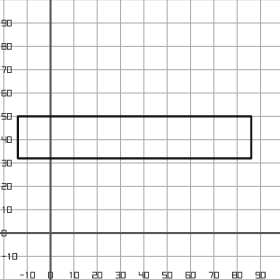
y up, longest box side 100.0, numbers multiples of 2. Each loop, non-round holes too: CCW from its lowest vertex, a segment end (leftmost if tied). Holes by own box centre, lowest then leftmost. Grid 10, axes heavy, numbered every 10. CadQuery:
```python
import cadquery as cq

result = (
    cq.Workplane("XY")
    .moveTo(-14.0, 32.0)
    .lineTo(86.0, 32.0)
    .lineTo(86.0, 50.0)
    .lineTo(-14.0, 50.0)
    .close()
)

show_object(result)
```